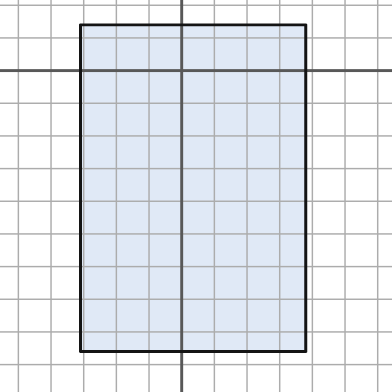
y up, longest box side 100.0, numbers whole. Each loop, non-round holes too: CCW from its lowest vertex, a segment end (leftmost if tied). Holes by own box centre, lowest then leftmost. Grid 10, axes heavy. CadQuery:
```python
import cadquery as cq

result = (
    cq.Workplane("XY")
    .moveTo(-31.0, -86.0)
    .lineTo(38.0, -86.0)
    .lineTo(38.0, 14.0)
    .lineTo(-31.0, 14.0)
    .close()
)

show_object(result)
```